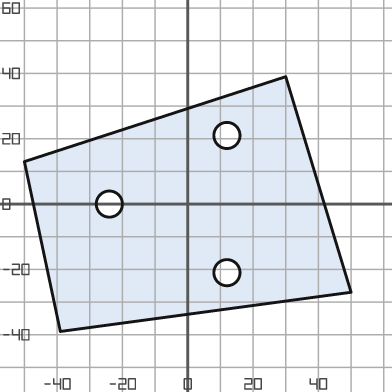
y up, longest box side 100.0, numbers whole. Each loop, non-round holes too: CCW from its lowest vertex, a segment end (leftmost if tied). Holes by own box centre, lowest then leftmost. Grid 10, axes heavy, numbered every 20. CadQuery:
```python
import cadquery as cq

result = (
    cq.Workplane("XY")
    .moveTo(-39.0, -39.0)
    .lineTo(50.0, -27.0)
    .lineTo(30.0, 39.0)
    .lineTo(-50.0, 13.0)
    .close()
    .moveTo(12.0, -21.0)
    .circle(4.0)
    .moveTo(-24.0, 0.0)
    .circle(4.0)
    .moveTo(12.0, 21.0)
    .circle(4.0)
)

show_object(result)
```